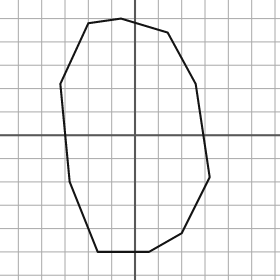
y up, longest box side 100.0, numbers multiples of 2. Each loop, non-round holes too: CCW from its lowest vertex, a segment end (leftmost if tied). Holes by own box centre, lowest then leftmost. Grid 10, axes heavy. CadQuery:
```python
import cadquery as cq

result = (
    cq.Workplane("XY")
    .moveTo(-16.0, -50.0)
    .lineTo(6.0, -50.0)
    .lineTo(20.0, -42.0)
    .lineTo(32.0, -18.0)
    .lineTo(26.0, 22.0)
    .lineTo(14.0, 44.0)
    .lineTo(-6.0, 50.0)
    .lineTo(-20.0, 48.0)
    .lineTo(-32.0, 22.0)
    .lineTo(-28.0, -20.0)
    .close()
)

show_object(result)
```